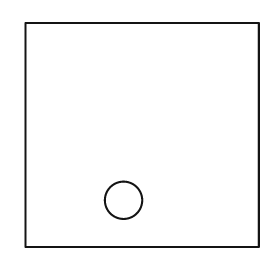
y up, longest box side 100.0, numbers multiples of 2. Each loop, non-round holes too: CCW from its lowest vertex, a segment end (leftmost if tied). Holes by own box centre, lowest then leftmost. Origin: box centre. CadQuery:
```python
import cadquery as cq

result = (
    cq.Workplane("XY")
    .moveTo(-50.0, -48.0)
    .lineTo(50.0, -48.0)
    .lineTo(50.0, 48.0)
    .lineTo(-50.0, 48.0)
    .close()
    .moveTo(-8.0, -28.0)
    .circle(8.0)
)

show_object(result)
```